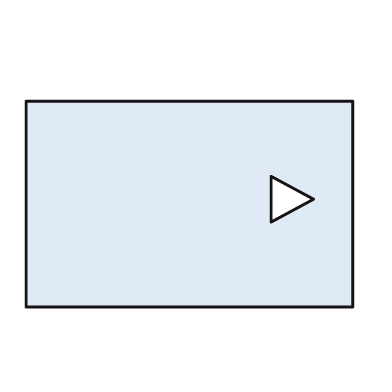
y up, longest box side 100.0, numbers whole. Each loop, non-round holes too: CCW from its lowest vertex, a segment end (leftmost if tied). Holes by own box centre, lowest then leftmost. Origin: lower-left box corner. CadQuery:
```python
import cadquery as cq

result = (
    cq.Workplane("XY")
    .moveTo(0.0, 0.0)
    .lineTo(100.0, 0.0)
    .lineTo(100.0, 63.0)
    .lineTo(0.0, 63.0)
    .close()
    .moveTo(75.0, 26.0)
    .lineTo(88.0, 33.0)
    .lineTo(75.0, 40.0)
    .close()
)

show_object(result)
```